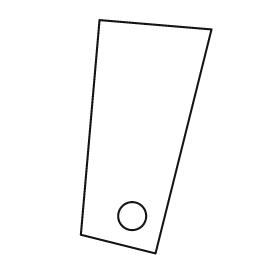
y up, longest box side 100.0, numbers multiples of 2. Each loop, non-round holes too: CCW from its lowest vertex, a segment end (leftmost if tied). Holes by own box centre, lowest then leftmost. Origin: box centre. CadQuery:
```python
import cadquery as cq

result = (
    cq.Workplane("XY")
    .moveTo(4.0, -50.0)
    .lineTo(28.0, 46.0)
    .lineTo(-20.0, 50.0)
    .lineTo(-28.0, -42.0)
    .close()
    .moveTo(-6.0, -34.0)
    .circle(6.0)
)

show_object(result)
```